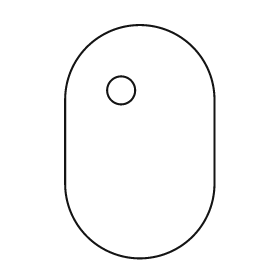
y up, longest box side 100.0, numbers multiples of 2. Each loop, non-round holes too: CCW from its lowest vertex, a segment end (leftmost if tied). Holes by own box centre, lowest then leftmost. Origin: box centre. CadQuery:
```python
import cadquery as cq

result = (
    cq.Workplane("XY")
    .moveTo(-32.0, -18.0)
    .threePointArc((0.0, -50.0), (32.0, -18.0))
    .lineTo(32.0, 18.0)
    .threePointArc((0.0, 50.0), (-32.0, 18.0))
    .close()
    .moveTo(-8.0, 22.0)
    .circle(6.0)
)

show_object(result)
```